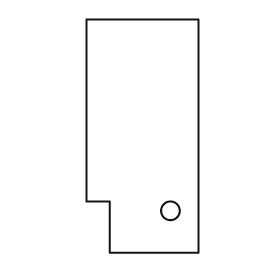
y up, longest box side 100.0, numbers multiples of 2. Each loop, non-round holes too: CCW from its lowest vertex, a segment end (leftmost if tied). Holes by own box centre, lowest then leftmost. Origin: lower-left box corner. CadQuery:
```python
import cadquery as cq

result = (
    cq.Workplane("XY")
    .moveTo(10.0, 0.0)
    .lineTo(48.0, 0.0)
    .lineTo(48.0, 100.0)
    .lineTo(0.0, 100.0)
    .lineTo(0.0, 22.0)
    .lineTo(10.0, 22.0)
    .close()
    .moveTo(36.0, 18.0)
    .circle(4.0)
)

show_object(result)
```